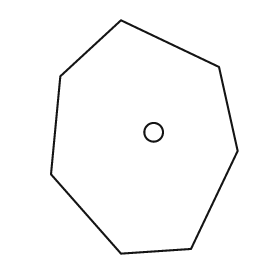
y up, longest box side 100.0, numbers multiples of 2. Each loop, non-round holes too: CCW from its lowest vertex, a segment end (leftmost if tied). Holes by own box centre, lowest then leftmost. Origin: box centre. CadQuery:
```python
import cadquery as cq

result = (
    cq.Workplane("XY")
    .moveTo(-10.0, -50.0)
    .lineTo(20.0, -48.0)
    .lineTo(40.0, -6.0)
    .lineTo(32.0, 30.0)
    .lineTo(-10.0, 50.0)
    .lineTo(-36.0, 26.0)
    .lineTo(-40.0, -16.0)
    .close()
    .moveTo(4.0, 2.0)
    .circle(4.0)
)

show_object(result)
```